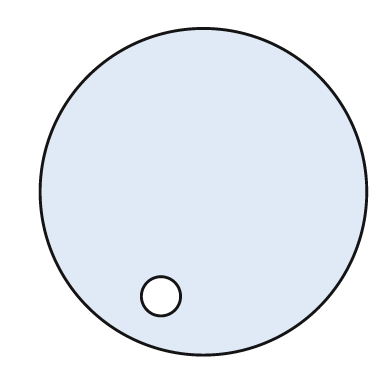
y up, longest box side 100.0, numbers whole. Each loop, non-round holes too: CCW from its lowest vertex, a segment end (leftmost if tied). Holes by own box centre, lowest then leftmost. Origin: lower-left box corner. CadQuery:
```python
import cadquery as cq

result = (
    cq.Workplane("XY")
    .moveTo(50.0, 50.0)
    .circle(50.0)
    .moveTo(37.0, 18.0)
    .circle(6.0)
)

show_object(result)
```